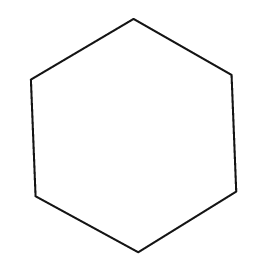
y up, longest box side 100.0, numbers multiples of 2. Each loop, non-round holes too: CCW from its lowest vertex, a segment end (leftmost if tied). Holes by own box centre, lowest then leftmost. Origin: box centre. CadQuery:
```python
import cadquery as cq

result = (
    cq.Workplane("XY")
    .moveTo(2.0, -50.0)
    .lineTo(44.0, -24.0)
    .lineTo(42.0, 26.0)
    .lineTo(0.0, 50.0)
    .lineTo(-44.0, 24.0)
    .lineTo(-42.0, -26.0)
    .close()
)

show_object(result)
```